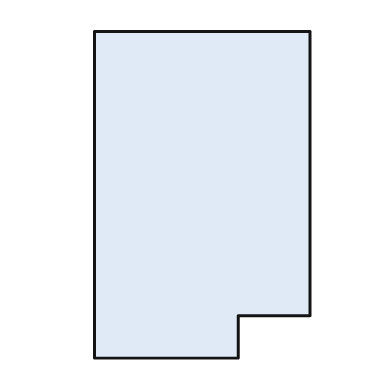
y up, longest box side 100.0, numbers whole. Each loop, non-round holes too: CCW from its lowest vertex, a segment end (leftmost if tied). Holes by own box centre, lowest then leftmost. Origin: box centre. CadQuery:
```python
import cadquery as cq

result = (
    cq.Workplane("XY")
    .moveTo(-33.0, -50.0)
    .lineTo(11.0, -50.0)
    .lineTo(11.0, -37.0)
    .lineTo(33.0, -37.0)
    .lineTo(33.0, 50.0)
    .lineTo(-33.0, 50.0)
    .close()
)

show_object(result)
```